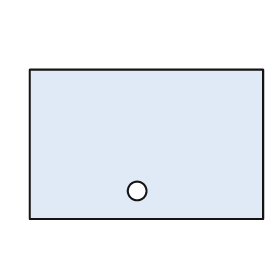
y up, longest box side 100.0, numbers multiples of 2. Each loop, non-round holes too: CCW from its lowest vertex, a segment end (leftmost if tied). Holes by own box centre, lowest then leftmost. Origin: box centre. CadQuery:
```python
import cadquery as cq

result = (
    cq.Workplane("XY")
    .moveTo(-50.0, -32.0)
    .lineTo(50.0, -32.0)
    .lineTo(50.0, 32.0)
    .lineTo(-50.0, 32.0)
    .close()
    .moveTo(-4.0, -20.0)
    .circle(4.0)
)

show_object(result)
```